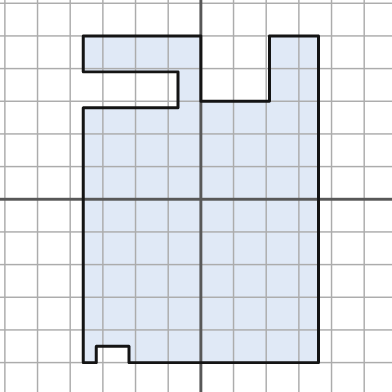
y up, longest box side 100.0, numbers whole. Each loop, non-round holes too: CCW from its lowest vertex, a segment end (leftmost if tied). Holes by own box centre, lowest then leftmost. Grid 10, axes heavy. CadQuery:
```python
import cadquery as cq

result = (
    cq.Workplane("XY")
    .moveTo(-36.0, -50.0)
    .lineTo(-32.0, -50.0)
    .lineTo(-32.0, -45.0)
    .lineTo(-22.0, -45.0)
    .lineTo(-22.0, -50.0)
    .lineTo(36.0, -50.0)
    .lineTo(36.0, 50.0)
    .lineTo(21.0, 50.0)
    .lineTo(21.0, 30.0)
    .lineTo(0.0, 30.0)
    .lineTo(0.0, 50.0)
    .lineTo(-36.0, 50.0)
    .lineTo(-36.0, 39.0)
    .lineTo(-7.0, 39.0)
    .lineTo(-7.0, 28.0)
    .lineTo(-36.0, 28.0)
    .close()
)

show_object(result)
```